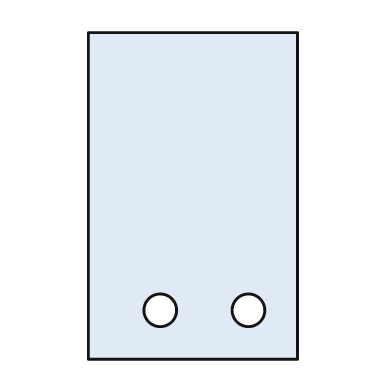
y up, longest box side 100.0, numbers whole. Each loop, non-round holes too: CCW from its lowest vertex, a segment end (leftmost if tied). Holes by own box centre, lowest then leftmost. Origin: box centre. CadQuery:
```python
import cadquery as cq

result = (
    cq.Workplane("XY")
    .moveTo(-32.0, -50.0)
    .lineTo(32.0, -50.0)
    .lineTo(32.0, 50.0)
    .lineTo(-32.0, 50.0)
    .close()
    .moveTo(-10.0, -35.0)
    .circle(5.0)
    .moveTo(17.0, -35.0)
    .circle(5.0)
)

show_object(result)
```